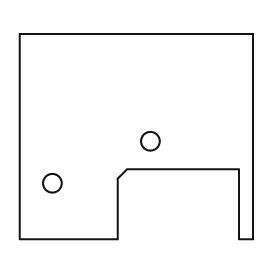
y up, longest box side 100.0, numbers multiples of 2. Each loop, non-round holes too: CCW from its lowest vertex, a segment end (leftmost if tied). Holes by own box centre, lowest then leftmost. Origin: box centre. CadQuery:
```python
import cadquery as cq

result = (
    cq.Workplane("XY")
    .moveTo(-50.0, -44.0)
    .lineTo(-8.0, -44.0)
    .lineTo(-8.0, -18.0)
    .lineTo(-4.0, -14.0)
    .lineTo(44.0, -14.0)
    .lineTo(44.0, -44.0)
    .lineTo(50.0, -44.0)
    .lineTo(50.0, 44.0)
    .lineTo(-50.0, 44.0)
    .close()
    .moveTo(-36.0, -20.0)
    .circle(4.0)
    .moveTo(6.0, -2.0)
    .circle(4.0)
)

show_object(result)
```